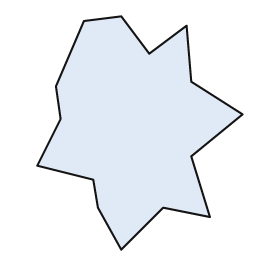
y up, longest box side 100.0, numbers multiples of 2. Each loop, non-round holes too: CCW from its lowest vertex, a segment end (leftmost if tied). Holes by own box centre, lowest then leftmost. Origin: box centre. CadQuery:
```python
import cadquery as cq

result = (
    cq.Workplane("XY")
    .moveTo(-8.0, -50.0)
    .lineTo(10.0, -32.0)
    .lineTo(30.0, -36.0)
    .lineTo(22.0, -10.0)
    .lineTo(44.0, 8.0)
    .lineTo(22.0, 22.0)
    .lineTo(20.0, 46.0)
    .lineTo(4.0, 34.0)
    .lineTo(-8.0, 50.0)
    .lineTo(-24.0, 48.0)
    .lineTo(-36.0, 20.0)
    .lineTo(-34.0, 6.0)
    .lineTo(-44.0, -14.0)
    .lineTo(-20.0, -20.0)
    .lineTo(-18.0, -32.0)
    .close()
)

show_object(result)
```